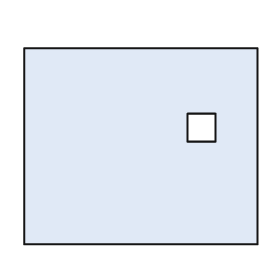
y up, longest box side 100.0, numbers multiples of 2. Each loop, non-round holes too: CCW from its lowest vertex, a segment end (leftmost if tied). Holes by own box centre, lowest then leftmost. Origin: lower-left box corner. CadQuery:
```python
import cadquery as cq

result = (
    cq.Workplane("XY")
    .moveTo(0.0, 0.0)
    .lineTo(100.0, 0.0)
    .lineTo(100.0, 84.0)
    .lineTo(0.0, 84.0)
    .close()
    .moveTo(70.0, 44.0)
    .lineTo(82.0, 44.0)
    .lineTo(82.0, 56.0)
    .lineTo(70.0, 56.0)
    .close()
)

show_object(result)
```